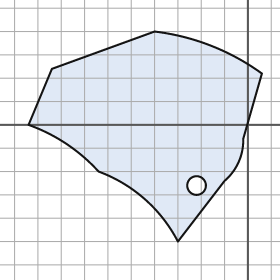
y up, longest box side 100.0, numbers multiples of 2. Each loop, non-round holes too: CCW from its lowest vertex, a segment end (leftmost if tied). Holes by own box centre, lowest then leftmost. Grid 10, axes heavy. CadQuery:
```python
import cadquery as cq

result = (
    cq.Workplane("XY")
    .moveTo(-30.0, -50.0)
    .lineTo(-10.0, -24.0)
    .threePointArc((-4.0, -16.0), (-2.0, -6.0))
    .lineTo(6.0, 22.0)
    .threePointArc((-16.0, 34.0), (-40.0, 40.0))
    .lineTo(-84.0, 24.0)
    .lineTo(-94.0, 0.0)
    .threePointArc((-78.0, -8.0), (-64.0, -20.0))
    .threePointArc((-44.0, -32.0), (-30.0, -50.0))
    .close()
    .moveTo(-22.0, -26.0)
    .circle(4.0)
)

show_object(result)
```